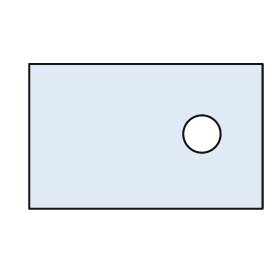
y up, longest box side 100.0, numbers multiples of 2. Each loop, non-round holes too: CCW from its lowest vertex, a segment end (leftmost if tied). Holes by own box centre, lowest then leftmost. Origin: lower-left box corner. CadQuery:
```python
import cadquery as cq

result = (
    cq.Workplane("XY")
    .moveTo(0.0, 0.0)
    .lineTo(100.0, 0.0)
    .lineTo(100.0, 62.0)
    .lineTo(0.0, 62.0)
    .close()
    .moveTo(74.0, 32.0)
    .circle(8.0)
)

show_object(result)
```